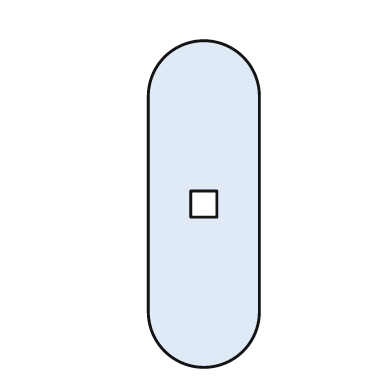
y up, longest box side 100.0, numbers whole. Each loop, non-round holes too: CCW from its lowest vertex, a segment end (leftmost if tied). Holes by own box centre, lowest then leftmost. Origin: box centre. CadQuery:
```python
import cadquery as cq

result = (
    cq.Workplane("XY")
    .moveTo(-17.0, -33.0)
    .threePointArc((0.0, -50.0), (17.0, -33.0))
    .lineTo(17.0, 33.0)
    .threePointArc((0.0, 50.0), (-17.0, 33.0))
    .close()
    .moveTo(-4.0, -4.0)
    .lineTo(4.0, -4.0)
    .lineTo(4.0, 4.0)
    .lineTo(-4.0, 4.0)
    .close()
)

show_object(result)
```